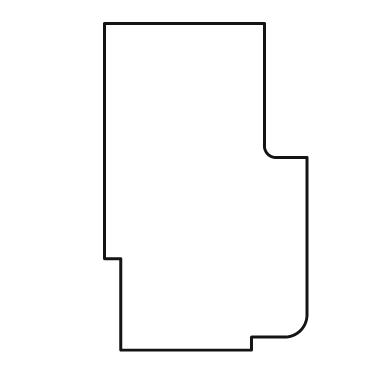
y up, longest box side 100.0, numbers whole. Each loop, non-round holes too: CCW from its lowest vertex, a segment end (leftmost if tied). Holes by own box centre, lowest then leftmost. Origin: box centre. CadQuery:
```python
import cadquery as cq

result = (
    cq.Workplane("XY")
    .moveTo(-26.0, -50.0)
    .lineTo(14.0, -50.0)
    .lineTo(14.0, -46.0)
    .lineTo(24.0, -46.0)
    .threePointArc((29.0, -44.0), (31.0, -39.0))
    .lineTo(31.0, 9.0)
    .lineTo(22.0, 9.0)
    .threePointArc((19.0, 10.0), (18.0, 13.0))
    .lineTo(18.0, 50.0)
    .lineTo(-31.0, 50.0)
    .lineTo(-31.0, -22.0)
    .lineTo(-26.0, -22.0)
    .close()
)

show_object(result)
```